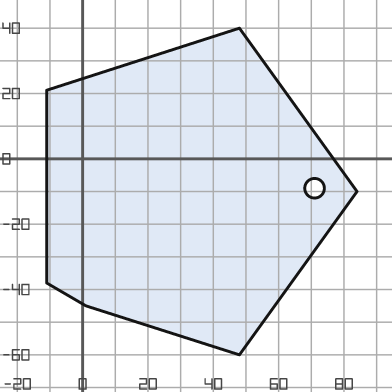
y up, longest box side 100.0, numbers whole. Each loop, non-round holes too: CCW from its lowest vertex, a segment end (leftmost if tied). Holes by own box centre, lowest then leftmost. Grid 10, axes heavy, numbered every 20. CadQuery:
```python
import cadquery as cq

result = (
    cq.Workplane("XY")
    .moveTo(48.0, -60.0)
    .lineTo(84.0, -10.0)
    .lineTo(48.0, 40.0)
    .lineTo(-11.0, 21.0)
    .lineTo(-11.0, -38.0)
    .lineTo(1.0, -45.0)
    .close()
    .moveTo(71.0, -9.0)
    .circle(3.0)
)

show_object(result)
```